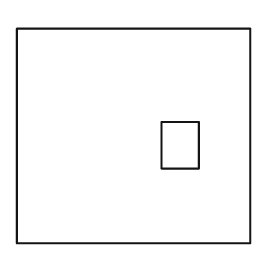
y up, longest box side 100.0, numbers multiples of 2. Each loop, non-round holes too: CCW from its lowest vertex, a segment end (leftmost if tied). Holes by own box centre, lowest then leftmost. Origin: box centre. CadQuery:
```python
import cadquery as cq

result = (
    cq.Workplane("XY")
    .moveTo(-50.0, -46.0)
    .lineTo(50.0, -46.0)
    .lineTo(50.0, 46.0)
    .lineTo(-50.0, 46.0)
    .close()
    .moveTo(12.0, -14.0)
    .lineTo(28.0, -14.0)
    .lineTo(28.0, 6.0)
    .lineTo(12.0, 6.0)
    .close()
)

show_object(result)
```